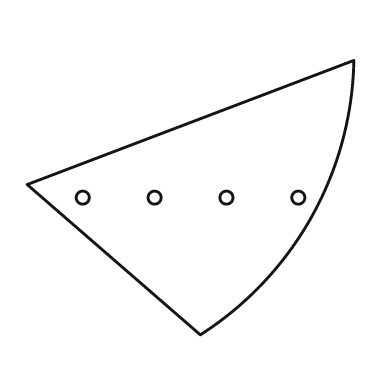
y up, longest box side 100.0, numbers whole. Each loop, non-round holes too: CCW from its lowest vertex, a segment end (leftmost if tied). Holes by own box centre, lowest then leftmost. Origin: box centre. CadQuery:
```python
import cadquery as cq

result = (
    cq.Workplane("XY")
    .moveTo(3.0, -42.0)
    .threePointArc((37.0, -6.0), (50.0, 42.0))
    .lineTo(-50.0, 4.0)
    .close()
    .moveTo(-33.0, 0.0)
    .circle(2.0)
    .moveTo(-11.0, 0.0)
    .circle(2.0)
    .moveTo(11.0, 0.0)
    .circle(2.0)
    .moveTo(33.0, 0.0)
    .circle(2.0)
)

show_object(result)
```